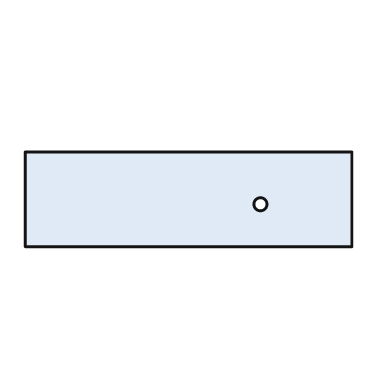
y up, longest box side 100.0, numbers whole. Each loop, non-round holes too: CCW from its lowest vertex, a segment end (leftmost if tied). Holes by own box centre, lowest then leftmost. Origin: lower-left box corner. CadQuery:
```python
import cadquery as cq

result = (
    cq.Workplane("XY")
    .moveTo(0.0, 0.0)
    .lineTo(100.0, 0.0)
    .lineTo(100.0, 29.0)
    .lineTo(0.0, 29.0)
    .close()
    .moveTo(72.0, 13.0)
    .circle(2.0)
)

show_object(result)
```